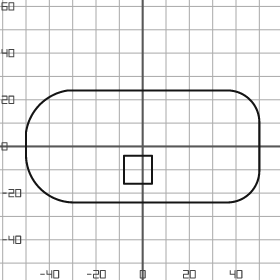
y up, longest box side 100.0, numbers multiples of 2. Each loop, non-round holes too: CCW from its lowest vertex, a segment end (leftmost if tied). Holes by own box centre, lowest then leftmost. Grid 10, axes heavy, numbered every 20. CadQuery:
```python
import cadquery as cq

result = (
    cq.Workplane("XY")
    .moveTo(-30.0, -24.0)
    .lineTo(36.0, -24.0)
    .threePointArc((46.0, -20.0), (50.0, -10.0))
    .lineTo(50.0, 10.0)
    .threePointArc((46.0, 20.0), (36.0, 24.0))
    .lineTo(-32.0, 24.0)
    .threePointArc((-44.0, 18.0), (-50.0, 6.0))
    .lineTo(-50.0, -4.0)
    .threePointArc((-44.0, -18.0), (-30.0, -24.0))
    .close()
    .moveTo(-8.0, -16.0)
    .lineTo(4.0, -16.0)
    .lineTo(4.0, -4.0)
    .lineTo(-8.0, -4.0)
    .close()
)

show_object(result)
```